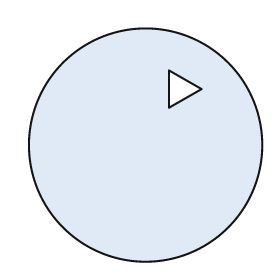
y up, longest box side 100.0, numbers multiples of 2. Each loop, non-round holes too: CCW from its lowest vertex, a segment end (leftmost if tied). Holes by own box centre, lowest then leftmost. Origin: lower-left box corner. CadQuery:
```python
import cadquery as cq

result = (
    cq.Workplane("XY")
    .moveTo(50.0, 50.0)
    .circle(50.0)
    .moveTo(60.0, 66.0)
    .lineTo(74.0, 74.0)
    .lineTo(60.0, 82.0)
    .close()
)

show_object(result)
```